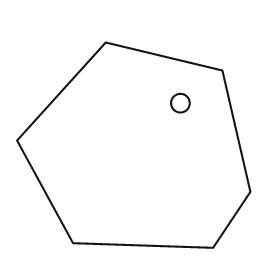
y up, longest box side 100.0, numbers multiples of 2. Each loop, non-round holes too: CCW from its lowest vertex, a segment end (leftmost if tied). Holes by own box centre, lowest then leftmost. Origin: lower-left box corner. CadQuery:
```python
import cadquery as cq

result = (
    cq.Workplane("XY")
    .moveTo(84.0, 0.0)
    .lineTo(100.0, 24.0)
    .lineTo(88.0, 76.0)
    .lineTo(38.0, 88.0)
    .lineTo(0.0, 46.0)
    .lineTo(24.0, 2.0)
    .close()
    .moveTo(70.0, 62.0)
    .circle(4.0)
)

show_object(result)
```